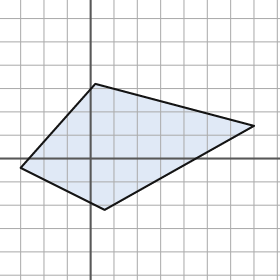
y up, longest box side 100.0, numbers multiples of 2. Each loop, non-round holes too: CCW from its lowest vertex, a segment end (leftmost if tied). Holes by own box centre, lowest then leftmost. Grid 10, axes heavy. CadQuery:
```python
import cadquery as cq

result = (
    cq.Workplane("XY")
    .moveTo(6.0, -22.0)
    .lineTo(70.0, 14.0)
    .lineTo(2.0, 32.0)
    .lineTo(-30.0, -4.0)
    .close()
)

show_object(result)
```